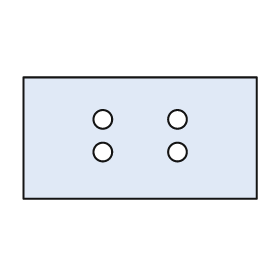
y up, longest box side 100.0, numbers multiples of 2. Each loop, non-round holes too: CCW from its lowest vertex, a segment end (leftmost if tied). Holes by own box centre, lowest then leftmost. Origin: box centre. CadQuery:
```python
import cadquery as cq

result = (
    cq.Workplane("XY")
    .moveTo(-50.0, -26.0)
    .lineTo(50.0, -26.0)
    .lineTo(50.0, 26.0)
    .lineTo(-50.0, 26.0)
    .close()
    .moveTo(-16.0, -6.0)
    .circle(4.0)
    .moveTo(16.0, -6.0)
    .circle(4.0)
    .moveTo(-16.0, 8.0)
    .circle(4.0)
    .moveTo(16.0, 8.0)
    .circle(4.0)
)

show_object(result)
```